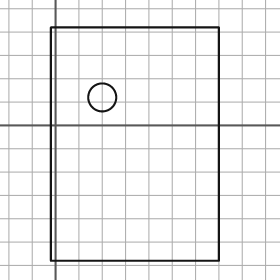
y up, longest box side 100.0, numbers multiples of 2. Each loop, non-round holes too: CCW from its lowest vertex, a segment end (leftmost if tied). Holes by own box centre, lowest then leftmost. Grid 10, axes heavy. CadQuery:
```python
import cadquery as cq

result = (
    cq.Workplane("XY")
    .moveTo(-2.0, -58.0)
    .lineTo(70.0, -58.0)
    .lineTo(70.0, 42.0)
    .lineTo(-2.0, 42.0)
    .close()
    .moveTo(20.0, 12.0)
    .circle(6.0)
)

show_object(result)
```